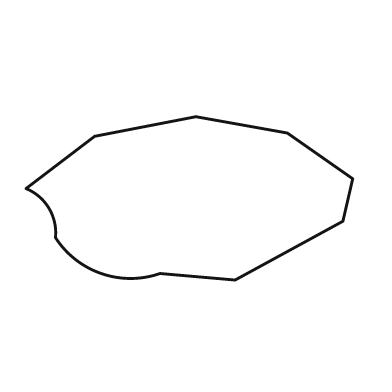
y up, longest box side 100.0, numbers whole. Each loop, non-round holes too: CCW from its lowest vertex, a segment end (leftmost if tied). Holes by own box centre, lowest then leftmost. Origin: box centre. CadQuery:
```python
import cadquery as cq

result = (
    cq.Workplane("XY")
    .moveTo(14.0, -25.0)
    .lineTo(47.0, -7.0)
    .lineTo(50.0, 6.0)
    .lineTo(30.0, 20.0)
    .lineTo(2.0, 25.0)
    .lineTo(-29.0, 19.0)
    .lineTo(-50.0, 3.0)
    .threePointArc((-43.0, -3.0), (-41.0, -12.0))
    .threePointArc((-27.0, -23.0), (-9.0, -23.0))
    .close()
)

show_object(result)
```